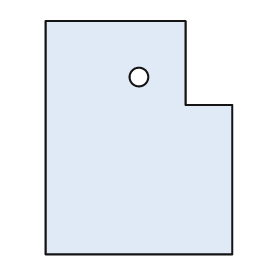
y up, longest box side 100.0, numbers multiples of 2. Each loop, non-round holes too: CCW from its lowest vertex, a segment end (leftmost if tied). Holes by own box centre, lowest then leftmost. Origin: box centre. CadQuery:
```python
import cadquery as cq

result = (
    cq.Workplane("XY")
    .moveTo(-40.0, -50.0)
    .lineTo(40.0, -50.0)
    .lineTo(40.0, 14.0)
    .lineTo(20.0, 14.0)
    .lineTo(20.0, 50.0)
    .lineTo(-40.0, 50.0)
    .close()
    .moveTo(0.0, 26.0)
    .circle(4.0)
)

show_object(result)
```